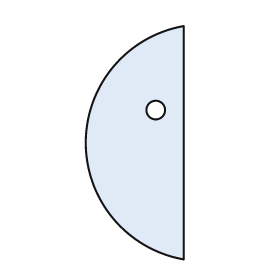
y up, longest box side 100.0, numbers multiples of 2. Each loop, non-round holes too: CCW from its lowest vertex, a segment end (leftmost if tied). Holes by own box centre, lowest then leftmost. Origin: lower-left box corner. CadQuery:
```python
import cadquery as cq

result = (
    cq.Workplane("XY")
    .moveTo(42.0, 0.0)
    .lineTo(42.0, 100.0)
    .threePointArc((0.0, 50.0), (42.0, 0.0))
    .close()
    .moveTo(30.0, 64.0)
    .circle(4.0)
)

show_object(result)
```